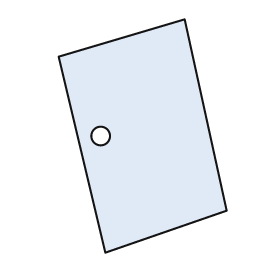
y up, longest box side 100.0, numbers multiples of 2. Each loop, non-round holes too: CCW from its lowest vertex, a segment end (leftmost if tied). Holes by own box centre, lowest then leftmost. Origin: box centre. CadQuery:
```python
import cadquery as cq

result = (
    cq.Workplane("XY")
    .moveTo(-16.0, -50.0)
    .lineTo(36.0, -32.0)
    .lineTo(18.0, 50.0)
    .lineTo(-36.0, 34.0)
    .close()
    .moveTo(-18.0, 0.0)
    .circle(4.0)
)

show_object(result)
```